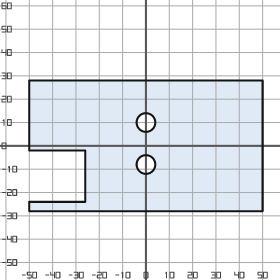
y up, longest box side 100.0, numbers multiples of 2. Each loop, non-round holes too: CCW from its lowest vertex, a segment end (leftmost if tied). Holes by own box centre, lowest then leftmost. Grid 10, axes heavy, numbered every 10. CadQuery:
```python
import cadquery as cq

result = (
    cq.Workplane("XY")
    .moveTo(-50.0, -28.0)
    .lineTo(50.0, -28.0)
    .lineTo(50.0, 28.0)
    .lineTo(-50.0, 28.0)
    .lineTo(-50.0, -2.0)
    .lineTo(-26.0, -2.0)
    .lineTo(-26.0, -24.0)
    .lineTo(-50.0, -24.0)
    .close()
    .moveTo(0.0, -8.0)
    .circle(4.0)
    .moveTo(0.0, 10.0)
    .circle(4.0)
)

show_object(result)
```